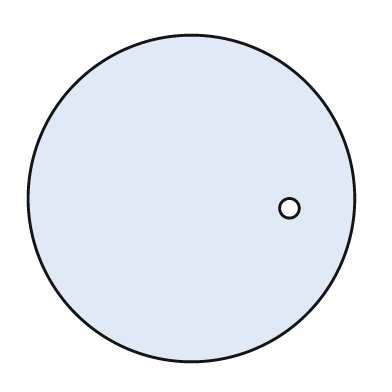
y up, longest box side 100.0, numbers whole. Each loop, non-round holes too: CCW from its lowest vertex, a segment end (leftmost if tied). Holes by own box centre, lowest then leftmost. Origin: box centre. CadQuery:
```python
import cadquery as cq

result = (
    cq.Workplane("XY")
    .moveTo(0.0, 0.0)
    .circle(50.0)
    .moveTo(30.0, -3.0)
    .circle(3.0)
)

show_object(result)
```